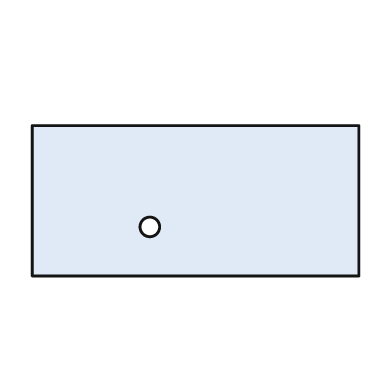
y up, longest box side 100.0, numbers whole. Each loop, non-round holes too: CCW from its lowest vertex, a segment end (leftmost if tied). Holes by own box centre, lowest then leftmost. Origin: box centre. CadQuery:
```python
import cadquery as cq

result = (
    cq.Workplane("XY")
    .moveTo(-50.0, -23.0)
    .lineTo(50.0, -23.0)
    .lineTo(50.0, 23.0)
    .lineTo(-50.0, 23.0)
    .close()
    .moveTo(-14.0, -8.0)
    .circle(3.0)
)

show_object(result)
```